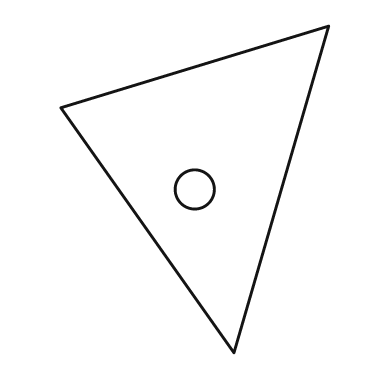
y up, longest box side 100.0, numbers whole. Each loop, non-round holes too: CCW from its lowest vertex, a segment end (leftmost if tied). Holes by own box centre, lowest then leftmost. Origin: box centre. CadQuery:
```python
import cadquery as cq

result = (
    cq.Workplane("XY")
    .moveTo(12.0, -50.0)
    .lineTo(41.0, 50.0)
    .lineTo(-41.0, 25.0)
    .close()
    .moveTo(0.0, 0.0)
    .circle(6.0)
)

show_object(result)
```